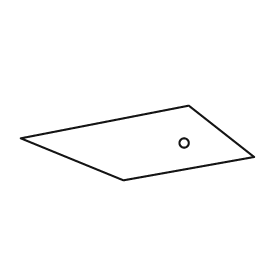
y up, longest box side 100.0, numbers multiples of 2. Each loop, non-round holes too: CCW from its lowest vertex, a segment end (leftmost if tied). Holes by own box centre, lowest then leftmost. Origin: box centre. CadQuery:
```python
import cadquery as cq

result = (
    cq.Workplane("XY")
    .moveTo(-6.0, -16.0)
    .lineTo(50.0, -6.0)
    .lineTo(22.0, 16.0)
    .lineTo(-50.0, 2.0)
    .close()
    .moveTo(20.0, 0.0)
    .circle(2.0)
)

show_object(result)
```